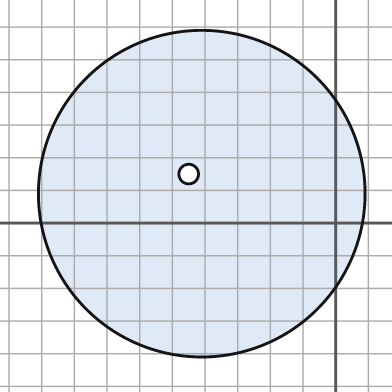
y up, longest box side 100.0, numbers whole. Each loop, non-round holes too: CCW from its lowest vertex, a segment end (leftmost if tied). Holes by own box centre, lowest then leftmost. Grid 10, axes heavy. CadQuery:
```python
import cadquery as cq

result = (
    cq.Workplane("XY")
    .moveTo(-41.0, 9.0)
    .circle(50.0)
    .moveTo(-45.0, 15.0)
    .circle(3.0)
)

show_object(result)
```